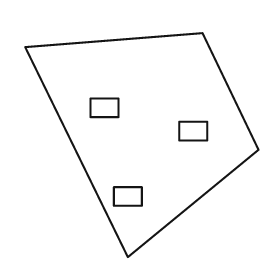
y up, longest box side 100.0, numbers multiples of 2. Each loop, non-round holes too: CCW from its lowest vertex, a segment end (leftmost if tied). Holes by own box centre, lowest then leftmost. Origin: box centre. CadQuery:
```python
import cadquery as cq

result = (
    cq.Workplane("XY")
    .moveTo(-6.0, -48.0)
    .lineTo(50.0, -2.0)
    .lineTo(26.0, 48.0)
    .lineTo(-50.0, 42.0)
    .close()
    .moveTo(-12.0, -26.0)
    .lineTo(0.0, -26.0)
    .lineTo(0.0, -18.0)
    .lineTo(-12.0, -18.0)
    .close()
    .moveTo(16.0, 2.0)
    .lineTo(28.0, 2.0)
    .lineTo(28.0, 10.0)
    .lineTo(16.0, 10.0)
    .close()
    .moveTo(-22.0, 12.0)
    .lineTo(-10.0, 12.0)
    .lineTo(-10.0, 20.0)
    .lineTo(-22.0, 20.0)
    .close()
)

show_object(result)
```